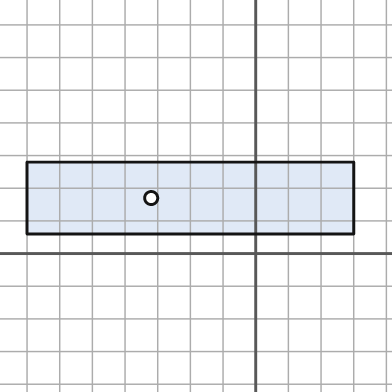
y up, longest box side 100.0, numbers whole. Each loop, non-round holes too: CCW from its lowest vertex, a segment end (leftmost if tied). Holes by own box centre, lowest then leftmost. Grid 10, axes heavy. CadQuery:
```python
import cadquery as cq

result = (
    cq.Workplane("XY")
    .moveTo(-70.0, 6.0)
    .lineTo(30.0, 6.0)
    .lineTo(30.0, 28.0)
    .lineTo(-70.0, 28.0)
    .close()
    .moveTo(-32.0, 17.0)
    .circle(2.0)
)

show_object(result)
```